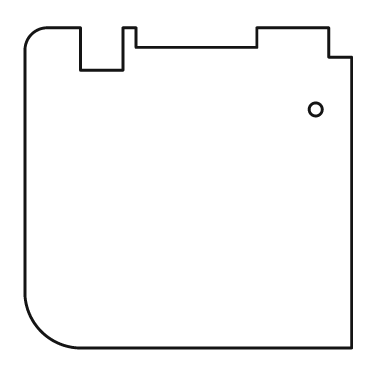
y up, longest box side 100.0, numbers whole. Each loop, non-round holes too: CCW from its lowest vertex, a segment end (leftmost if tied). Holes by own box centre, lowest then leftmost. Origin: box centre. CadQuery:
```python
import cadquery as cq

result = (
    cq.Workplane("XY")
    .moveTo(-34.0, -49.0)
    .lineTo(50.0, -49.0)
    .lineTo(50.0, 40.0)
    .lineTo(43.0, 40.0)
    .lineTo(43.0, 49.0)
    .lineTo(21.0, 49.0)
    .lineTo(21.0, 43.0)
    .lineTo(-16.0, 43.0)
    .lineTo(-16.0, 49.0)
    .lineTo(-20.0, 49.0)
    .lineTo(-20.0, 36.0)
    .lineTo(-33.0, 36.0)
    .lineTo(-33.0, 49.0)
    .lineTo(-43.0, 49.0)
    .threePointArc((-48.0, 47.0), (-50.0, 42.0))
    .lineTo(-50.0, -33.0)
    .threePointArc((-45.0, -44.0), (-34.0, -49.0))
    .close()
    .moveTo(39.0, 24.0)
    .circle(2.0)
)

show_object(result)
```